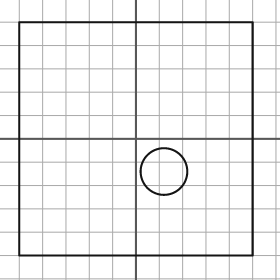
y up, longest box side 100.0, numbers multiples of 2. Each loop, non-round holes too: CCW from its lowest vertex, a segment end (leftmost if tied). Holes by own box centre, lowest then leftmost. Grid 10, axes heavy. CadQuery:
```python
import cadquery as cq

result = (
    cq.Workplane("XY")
    .moveTo(-50.0, -50.0)
    .lineTo(50.0, -50.0)
    .lineTo(50.0, 50.0)
    .lineTo(-50.0, 50.0)
    .close()
    .moveTo(12.0, -14.0)
    .circle(10.0)
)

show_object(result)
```